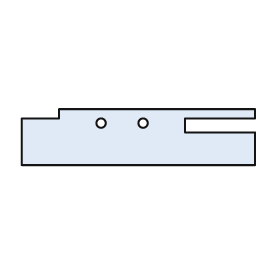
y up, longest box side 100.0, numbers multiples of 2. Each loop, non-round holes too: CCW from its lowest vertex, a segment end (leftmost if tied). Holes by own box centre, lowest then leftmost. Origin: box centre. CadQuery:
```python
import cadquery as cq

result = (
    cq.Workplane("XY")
    .moveTo(-50.0, -12.0)
    .lineTo(50.0, -12.0)
    .lineTo(50.0, 2.0)
    .lineTo(20.0, 2.0)
    .lineTo(20.0, 8.0)
    .lineTo(50.0, 8.0)
    .lineTo(50.0, 12.0)
    .lineTo(-34.0, 12.0)
    .lineTo(-34.0, 8.0)
    .lineTo(-50.0, 8.0)
    .close()
    .moveTo(-16.0, 6.0)
    .circle(2.0)
    .moveTo(2.0, 6.0)
    .circle(2.0)
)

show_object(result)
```